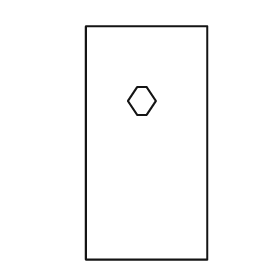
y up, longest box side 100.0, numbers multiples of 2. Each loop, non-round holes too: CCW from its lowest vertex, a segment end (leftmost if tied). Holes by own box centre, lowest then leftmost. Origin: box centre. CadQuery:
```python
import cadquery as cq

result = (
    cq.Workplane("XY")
    .moveTo(-26.0, -50.0)
    .lineTo(26.0, -50.0)
    .lineTo(26.0, 50.0)
    .lineTo(-26.0, 50.0)
    .close()
    .moveTo(-4.0, 12.0)
    .lineTo(0.0, 12.0)
    .lineTo(4.0, 18.0)
    .lineTo(0.0, 24.0)
    .lineTo(-4.0, 24.0)
    .lineTo(-8.0, 18.0)
    .close()
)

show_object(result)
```